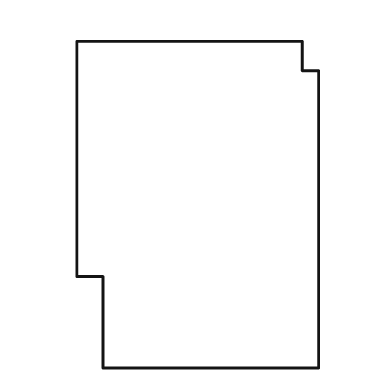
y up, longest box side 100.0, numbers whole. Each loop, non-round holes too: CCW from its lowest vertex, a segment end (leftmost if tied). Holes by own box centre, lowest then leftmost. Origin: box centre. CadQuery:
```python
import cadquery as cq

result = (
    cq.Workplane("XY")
    .moveTo(-29.0, -50.0)
    .lineTo(37.0, -50.0)
    .lineTo(37.0, 41.0)
    .lineTo(32.0, 41.0)
    .lineTo(32.0, 50.0)
    .lineTo(-37.0, 50.0)
    .lineTo(-37.0, -22.0)
    .lineTo(-29.0, -22.0)
    .close()
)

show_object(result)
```